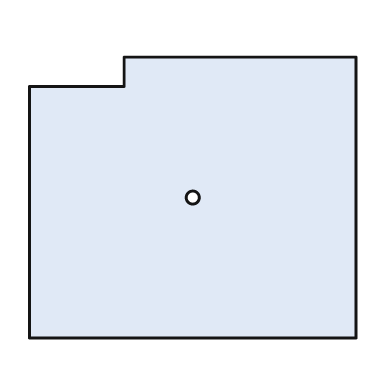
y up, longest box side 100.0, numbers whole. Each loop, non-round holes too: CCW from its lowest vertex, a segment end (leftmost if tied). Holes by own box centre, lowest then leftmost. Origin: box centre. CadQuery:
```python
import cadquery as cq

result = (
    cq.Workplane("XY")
    .moveTo(-50.0, -43.0)
    .lineTo(50.0, -43.0)
    .lineTo(50.0, 43.0)
    .lineTo(-21.0, 43.0)
    .lineTo(-21.0, 34.0)
    .lineTo(-50.0, 34.0)
    .close()
    .moveTo(0.0, 0.0)
    .circle(2.0)
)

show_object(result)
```